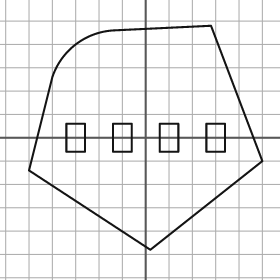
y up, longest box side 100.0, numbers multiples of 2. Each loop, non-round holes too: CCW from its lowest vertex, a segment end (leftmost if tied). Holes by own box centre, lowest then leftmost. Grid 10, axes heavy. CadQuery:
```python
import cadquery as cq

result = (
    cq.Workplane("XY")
    .moveTo(2.0, -48.0)
    .lineTo(50.0, -10.0)
    .lineTo(28.0, 48.0)
    .lineTo(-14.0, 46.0)
    .threePointArc((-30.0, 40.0), (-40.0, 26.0))
    .lineTo(-50.0, -14.0)
    .close()
    .moveTo(-34.0, -6.0)
    .lineTo(-26.0, -6.0)
    .lineTo(-26.0, 6.0)
    .lineTo(-34.0, 6.0)
    .close()
    .moveTo(-14.0, -6.0)
    .lineTo(-6.0, -6.0)
    .lineTo(-6.0, 6.0)
    .lineTo(-14.0, 6.0)
    .close()
    .moveTo(6.0, -6.0)
    .lineTo(14.0, -6.0)
    .lineTo(14.0, 6.0)
    .lineTo(6.0, 6.0)
    .close()
    .moveTo(26.0, -6.0)
    .lineTo(34.0, -6.0)
    .lineTo(34.0, 6.0)
    .lineTo(26.0, 6.0)
    .close()
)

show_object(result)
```